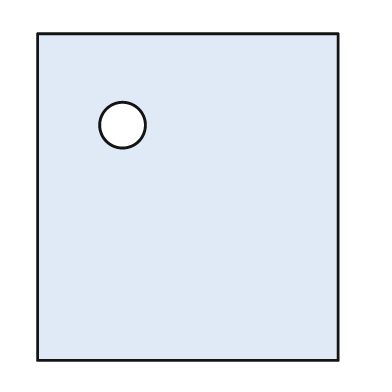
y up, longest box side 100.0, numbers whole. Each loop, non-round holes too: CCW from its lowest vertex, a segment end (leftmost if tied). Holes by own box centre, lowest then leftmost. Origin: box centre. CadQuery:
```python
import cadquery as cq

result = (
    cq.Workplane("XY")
    .moveTo(-46.0, -50.0)
    .lineTo(46.0, -50.0)
    .lineTo(46.0, 50.0)
    .lineTo(-46.0, 50.0)
    .close()
    .moveTo(-20.0, 22.0)
    .circle(7.0)
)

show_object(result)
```